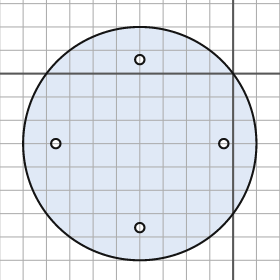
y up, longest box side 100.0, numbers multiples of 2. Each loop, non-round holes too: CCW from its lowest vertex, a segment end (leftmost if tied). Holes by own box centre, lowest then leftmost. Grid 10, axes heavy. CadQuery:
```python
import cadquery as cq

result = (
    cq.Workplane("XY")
    .moveTo(-40.0, -30.0)
    .circle(50.0)
    .moveTo(-40.0, -66.0)
    .circle(2.0)
    .moveTo(-76.0, -30.0)
    .circle(2.0)
    .moveTo(-4.0, -30.0)
    .circle(2.0)
    .moveTo(-40.0, 6.0)
    .circle(2.0)
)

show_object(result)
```